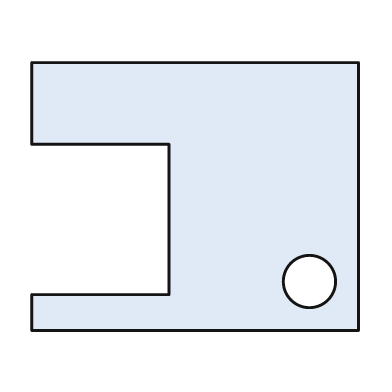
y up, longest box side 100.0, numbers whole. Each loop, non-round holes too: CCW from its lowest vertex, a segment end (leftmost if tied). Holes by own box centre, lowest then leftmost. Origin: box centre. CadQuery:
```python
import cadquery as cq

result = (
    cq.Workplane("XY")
    .moveTo(-50.0, -41.0)
    .lineTo(50.0, -41.0)
    .lineTo(50.0, 41.0)
    .lineTo(-50.0, 41.0)
    .lineTo(-50.0, 16.0)
    .lineTo(-8.0, 16.0)
    .lineTo(-8.0, -30.0)
    .lineTo(-50.0, -30.0)
    .close()
    .moveTo(35.0, -26.0)
    .circle(8.0)
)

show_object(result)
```